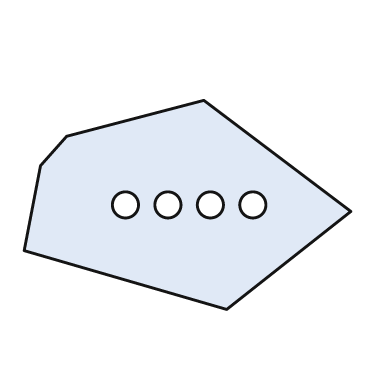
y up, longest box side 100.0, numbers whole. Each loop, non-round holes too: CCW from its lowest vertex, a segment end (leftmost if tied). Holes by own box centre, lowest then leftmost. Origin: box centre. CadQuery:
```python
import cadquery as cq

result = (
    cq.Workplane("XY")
    .moveTo(12.0, -32.0)
    .lineTo(50.0, -2.0)
    .lineTo(5.0, 32.0)
    .lineTo(-37.0, 21.0)
    .lineTo(-45.0, 12.0)
    .lineTo(-50.0, -14.0)
    .close()
    .moveTo(-19.0, 0.0)
    .circle(4.0)
    .moveTo(-6.0, 0.0)
    .circle(4.0)
    .moveTo(7.0, 0.0)
    .circle(4.0)
    .moveTo(20.0, 0.0)
    .circle(4.0)
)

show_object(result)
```